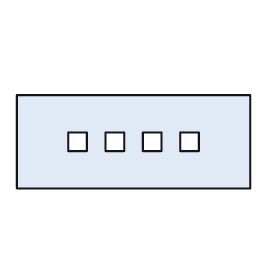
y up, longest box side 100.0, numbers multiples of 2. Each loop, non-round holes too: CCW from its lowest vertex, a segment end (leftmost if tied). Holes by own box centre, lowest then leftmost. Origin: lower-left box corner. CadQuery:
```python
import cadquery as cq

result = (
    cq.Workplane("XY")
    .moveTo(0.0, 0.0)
    .lineTo(100.0, 0.0)
    .lineTo(100.0, 40.0)
    .lineTo(0.0, 40.0)
    .close()
    .moveTo(22.0, 16.0)
    .lineTo(30.0, 16.0)
    .lineTo(30.0, 24.0)
    .lineTo(22.0, 24.0)
    .close()
    .moveTo(38.0, 16.0)
    .lineTo(46.0, 16.0)
    .lineTo(46.0, 24.0)
    .lineTo(38.0, 24.0)
    .close()
    .moveTo(54.0, 16.0)
    .lineTo(62.0, 16.0)
    .lineTo(62.0, 24.0)
    .lineTo(54.0, 24.0)
    .close()
    .moveTo(70.0, 16.0)
    .lineTo(78.0, 16.0)
    .lineTo(78.0, 24.0)
    .lineTo(70.0, 24.0)
    .close()
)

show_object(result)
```